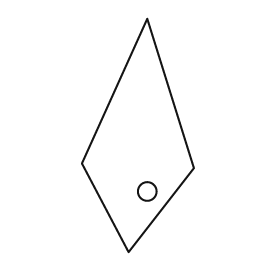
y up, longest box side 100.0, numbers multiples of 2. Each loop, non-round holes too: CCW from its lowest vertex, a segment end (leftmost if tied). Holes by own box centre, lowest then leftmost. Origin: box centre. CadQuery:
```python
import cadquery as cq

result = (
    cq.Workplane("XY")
    .moveTo(-4.0, -50.0)
    .lineTo(24.0, -14.0)
    .lineTo(4.0, 50.0)
    .lineTo(-24.0, -12.0)
    .close()
    .moveTo(4.0, -24.0)
    .circle(4.0)
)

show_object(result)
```